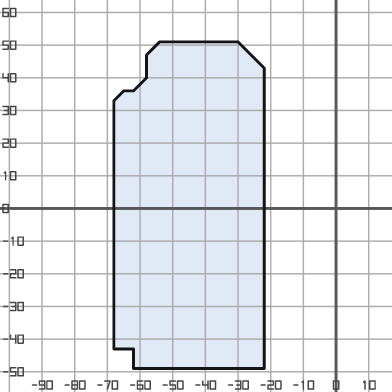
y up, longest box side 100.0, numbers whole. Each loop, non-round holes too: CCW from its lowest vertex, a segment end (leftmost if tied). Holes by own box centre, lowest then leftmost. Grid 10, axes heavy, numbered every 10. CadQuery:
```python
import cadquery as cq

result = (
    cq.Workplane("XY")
    .moveTo(-62.0, -49.0)
    .lineTo(-22.0, -49.0)
    .lineTo(-22.0, 43.0)
    .lineTo(-30.0, 51.0)
    .lineTo(-54.0, 51.0)
    .lineTo(-58.0, 47.0)
    .lineTo(-58.0, 40.0)
    .lineTo(-62.0, 36.0)
    .lineTo(-65.0, 36.0)
    .lineTo(-68.0, 33.0)
    .lineTo(-68.0, -43.0)
    .lineTo(-62.0, -43.0)
    .close()
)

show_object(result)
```